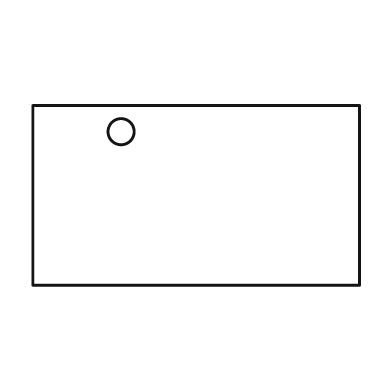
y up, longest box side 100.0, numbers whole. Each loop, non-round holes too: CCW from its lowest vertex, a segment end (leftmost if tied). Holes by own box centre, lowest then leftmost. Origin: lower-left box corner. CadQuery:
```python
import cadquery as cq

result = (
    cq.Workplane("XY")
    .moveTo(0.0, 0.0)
    .lineTo(100.0, 0.0)
    .lineTo(100.0, 55.0)
    .lineTo(0.0, 55.0)
    .close()
    .moveTo(27.0, 47.0)
    .circle(4.0)
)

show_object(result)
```